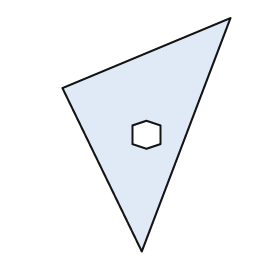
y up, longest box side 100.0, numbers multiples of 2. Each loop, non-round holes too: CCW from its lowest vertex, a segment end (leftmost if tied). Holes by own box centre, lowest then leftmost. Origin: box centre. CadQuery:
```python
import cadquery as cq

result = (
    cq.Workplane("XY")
    .moveTo(-2.0, -50.0)
    .lineTo(36.0, 50.0)
    .lineTo(-36.0, 20.0)
    .close()
    .moveTo(0.0, -6.0)
    .lineTo(6.0, -4.0)
    .lineTo(6.0, 4.0)
    .lineTo(0.0, 6.0)
    .lineTo(-6.0, 4.0)
    .lineTo(-6.0, -4.0)
    .close()
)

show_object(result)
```